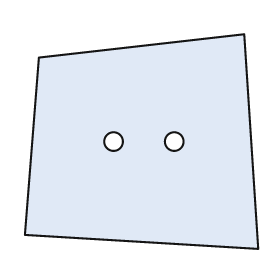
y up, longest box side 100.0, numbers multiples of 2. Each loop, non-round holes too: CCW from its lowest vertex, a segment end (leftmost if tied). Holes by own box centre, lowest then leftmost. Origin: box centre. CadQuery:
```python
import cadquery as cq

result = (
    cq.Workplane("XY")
    .moveTo(50.0, -46.0)
    .lineTo(44.0, 46.0)
    .lineTo(-44.0, 36.0)
    .lineTo(-50.0, -40.0)
    .close()
    .moveTo(-12.0, 0.0)
    .circle(4.0)
    .moveTo(14.0, 0.0)
    .circle(4.0)
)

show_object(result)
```